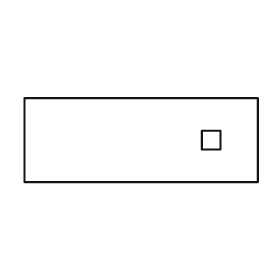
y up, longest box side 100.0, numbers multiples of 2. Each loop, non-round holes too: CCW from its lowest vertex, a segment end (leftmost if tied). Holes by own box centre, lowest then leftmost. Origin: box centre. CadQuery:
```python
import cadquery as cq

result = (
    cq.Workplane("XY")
    .moveTo(-50.0, -18.0)
    .lineTo(50.0, -18.0)
    .lineTo(50.0, 18.0)
    .lineTo(-50.0, 18.0)
    .close()
    .moveTo(26.0, -4.0)
    .lineTo(34.0, -4.0)
    .lineTo(34.0, 4.0)
    .lineTo(26.0, 4.0)
    .close()
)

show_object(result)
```